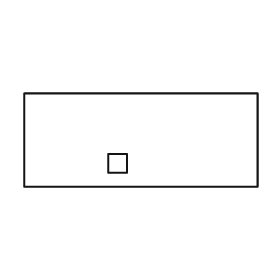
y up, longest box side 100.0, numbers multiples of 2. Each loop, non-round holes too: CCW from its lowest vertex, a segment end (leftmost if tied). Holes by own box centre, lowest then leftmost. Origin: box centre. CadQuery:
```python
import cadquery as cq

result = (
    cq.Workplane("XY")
    .moveTo(-50.0, -20.0)
    .lineTo(50.0, -20.0)
    .lineTo(50.0, 20.0)
    .lineTo(-50.0, 20.0)
    .close()
    .moveTo(-14.0, -14.0)
    .lineTo(-6.0, -14.0)
    .lineTo(-6.0, -6.0)
    .lineTo(-14.0, -6.0)
    .close()
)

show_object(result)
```